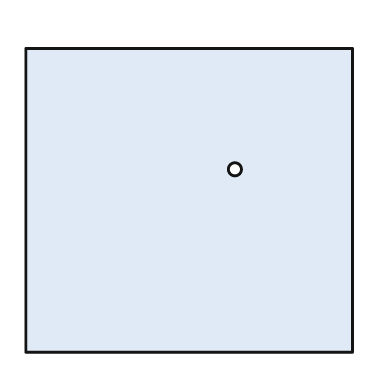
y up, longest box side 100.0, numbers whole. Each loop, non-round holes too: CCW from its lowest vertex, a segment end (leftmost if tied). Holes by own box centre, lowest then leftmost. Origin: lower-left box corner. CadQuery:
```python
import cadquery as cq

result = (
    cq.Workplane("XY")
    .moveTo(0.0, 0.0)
    .lineTo(100.0, 0.0)
    .lineTo(100.0, 93.0)
    .lineTo(0.0, 93.0)
    .close()
    .moveTo(64.0, 56.0)
    .circle(2.0)
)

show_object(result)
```